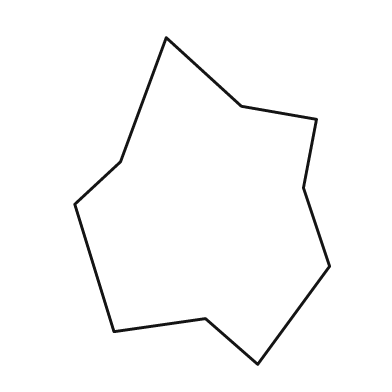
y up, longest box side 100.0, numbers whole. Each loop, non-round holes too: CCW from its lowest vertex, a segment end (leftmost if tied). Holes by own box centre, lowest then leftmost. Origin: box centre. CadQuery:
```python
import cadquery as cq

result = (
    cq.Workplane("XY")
    .moveTo(17.0, -50.0)
    .lineTo(39.0, -20.0)
    .lineTo(31.0, 4.0)
    .lineTo(35.0, 25.0)
    .lineTo(12.0, 29.0)
    .lineTo(-11.0, 50.0)
    .lineTo(-25.0, 12.0)
    .lineTo(-39.0, -1.0)
    .lineTo(-27.0, -40.0)
    .lineTo(1.0, -36.0)
    .close()
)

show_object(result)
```